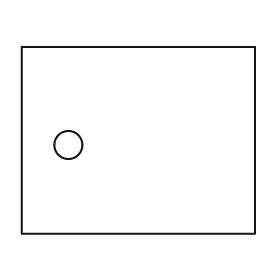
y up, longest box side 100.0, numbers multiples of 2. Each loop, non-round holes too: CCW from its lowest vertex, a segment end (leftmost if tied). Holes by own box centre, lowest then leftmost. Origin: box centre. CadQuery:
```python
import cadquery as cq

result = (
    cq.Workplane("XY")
    .moveTo(-50.0, -40.0)
    .lineTo(50.0, -40.0)
    .lineTo(50.0, 40.0)
    .lineTo(-50.0, 40.0)
    .close()
    .moveTo(-30.0, -2.0)
    .circle(6.0)
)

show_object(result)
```